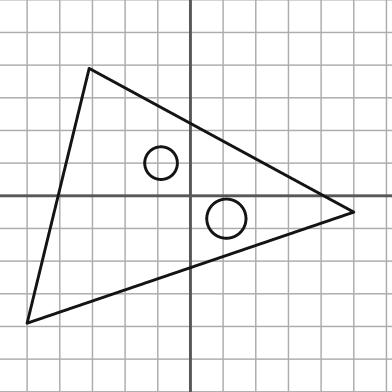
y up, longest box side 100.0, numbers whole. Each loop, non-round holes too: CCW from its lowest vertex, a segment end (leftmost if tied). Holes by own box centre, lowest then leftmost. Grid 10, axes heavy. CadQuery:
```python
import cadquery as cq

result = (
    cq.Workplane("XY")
    .moveTo(-50.0, -39.0)
    .lineTo(50.0, -5.0)
    .lineTo(-31.0, 39.0)
    .close()
    .moveTo(11.0, -7.0)
    .circle(6.0)
    .moveTo(-9.0, 10.0)
    .circle(5.0)
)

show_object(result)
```